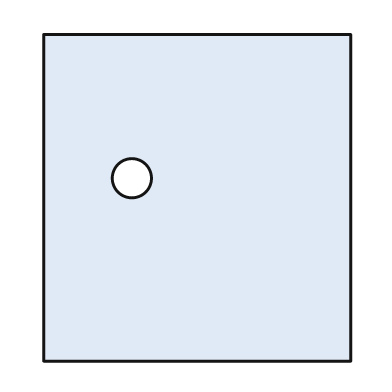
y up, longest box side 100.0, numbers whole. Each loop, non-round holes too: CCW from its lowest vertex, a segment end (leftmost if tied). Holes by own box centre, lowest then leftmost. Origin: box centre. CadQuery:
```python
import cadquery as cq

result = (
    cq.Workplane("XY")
    .moveTo(-47.0, -50.0)
    .lineTo(47.0, -50.0)
    .lineTo(47.0, 50.0)
    .lineTo(-47.0, 50.0)
    .close()
    .moveTo(-20.0, 6.0)
    .circle(6.0)
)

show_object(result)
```